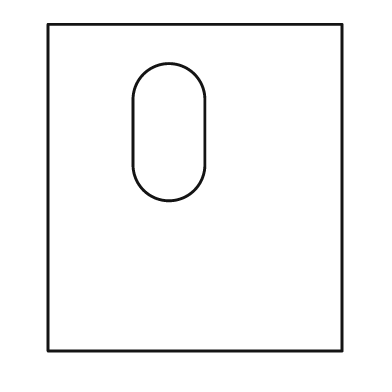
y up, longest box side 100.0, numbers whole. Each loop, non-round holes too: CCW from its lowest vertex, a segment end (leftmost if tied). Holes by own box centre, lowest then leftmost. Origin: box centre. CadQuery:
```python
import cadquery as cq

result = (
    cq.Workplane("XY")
    .moveTo(-45.0, -50.0)
    .lineTo(45.0, -50.0)
    .lineTo(45.0, 50.0)
    .lineTo(-45.0, 50.0)
    .close()
    .moveTo(-19.0, 7.0)
    .threePointArc((-8.0, -4.0), (3.0, 7.0))
    .lineTo(3.0, 27.0)
    .threePointArc((-8.0, 38.0), (-19.0, 27.0))
    .close()
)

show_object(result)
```